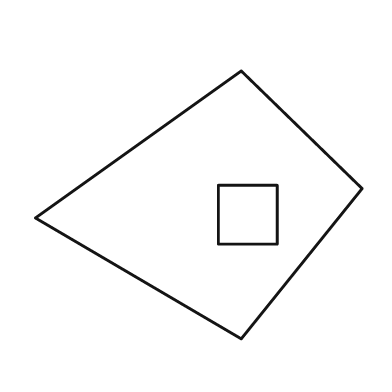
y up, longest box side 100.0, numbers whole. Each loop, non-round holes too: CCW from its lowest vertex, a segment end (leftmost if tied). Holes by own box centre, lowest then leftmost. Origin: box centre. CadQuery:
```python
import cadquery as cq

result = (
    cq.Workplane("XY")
    .moveTo(13.0, -41.0)
    .lineTo(50.0, 5.0)
    .lineTo(13.0, 41.0)
    .lineTo(-50.0, -4.0)
    .close()
    .moveTo(6.0, -12.0)
    .lineTo(24.0, -12.0)
    .lineTo(24.0, 6.0)
    .lineTo(6.0, 6.0)
    .close()
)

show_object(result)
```